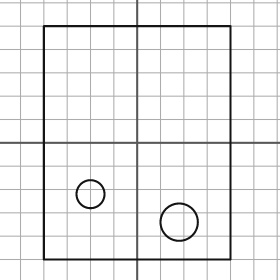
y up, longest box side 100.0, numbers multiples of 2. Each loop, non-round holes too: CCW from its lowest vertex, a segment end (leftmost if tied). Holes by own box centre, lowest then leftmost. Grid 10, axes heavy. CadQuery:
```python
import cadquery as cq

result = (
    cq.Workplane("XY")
    .moveTo(-40.0, -50.0)
    .lineTo(40.0, -50.0)
    .lineTo(40.0, 50.0)
    .lineTo(-40.0, 50.0)
    .close()
    .moveTo(18.0, -34.0)
    .circle(8.0)
    .moveTo(-20.0, -22.0)
    .circle(6.0)
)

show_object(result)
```